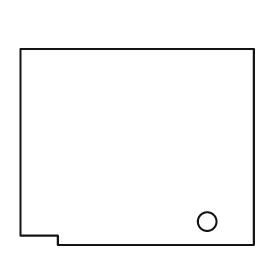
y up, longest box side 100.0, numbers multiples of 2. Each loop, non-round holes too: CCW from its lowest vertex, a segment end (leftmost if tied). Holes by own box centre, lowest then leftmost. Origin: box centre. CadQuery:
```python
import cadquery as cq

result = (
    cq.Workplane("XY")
    .moveTo(-34.0, -42.0)
    .lineTo(50.0, -42.0)
    .lineTo(50.0, 42.0)
    .lineTo(-50.0, 42.0)
    .lineTo(-50.0, -38.0)
    .lineTo(-34.0, -38.0)
    .close()
    .moveTo(30.0, -32.0)
    .circle(4.0)
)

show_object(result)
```